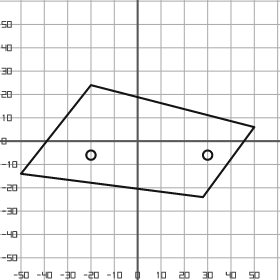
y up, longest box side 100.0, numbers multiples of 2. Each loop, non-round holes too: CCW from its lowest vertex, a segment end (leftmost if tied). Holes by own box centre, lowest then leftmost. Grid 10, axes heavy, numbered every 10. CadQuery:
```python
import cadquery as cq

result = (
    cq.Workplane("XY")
    .moveTo(28.0, -24.0)
    .lineTo(50.0, 6.0)
    .lineTo(-20.0, 24.0)
    .lineTo(-50.0, -14.0)
    .close()
    .moveTo(-20.0, -6.0)
    .circle(2.0)
    .moveTo(30.0, -6.0)
    .circle(2.0)
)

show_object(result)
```